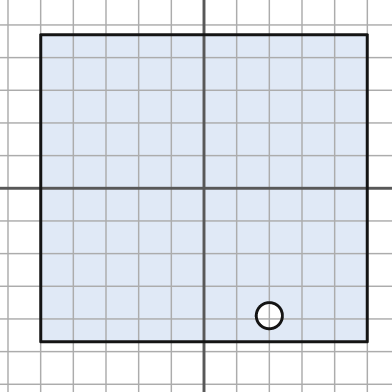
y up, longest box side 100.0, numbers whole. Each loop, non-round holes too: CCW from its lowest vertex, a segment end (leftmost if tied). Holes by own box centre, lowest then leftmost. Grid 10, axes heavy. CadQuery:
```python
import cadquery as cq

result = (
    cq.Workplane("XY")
    .moveTo(-50.0, -47.0)
    .lineTo(50.0, -47.0)
    .lineTo(50.0, 47.0)
    .lineTo(-50.0, 47.0)
    .close()
    .moveTo(20.0, -39.0)
    .circle(4.0)
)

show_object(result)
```